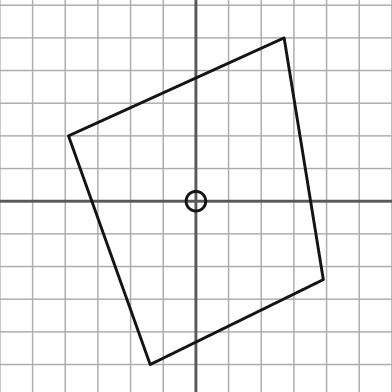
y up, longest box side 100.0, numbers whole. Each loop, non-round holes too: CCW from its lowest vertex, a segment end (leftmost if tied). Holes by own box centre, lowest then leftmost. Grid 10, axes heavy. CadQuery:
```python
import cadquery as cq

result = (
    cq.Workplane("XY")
    .moveTo(-14.0, -50.0)
    .lineTo(39.0, -24.0)
    .lineTo(27.0, 50.0)
    .lineTo(-39.0, 20.0)
    .close()
    .moveTo(0.0, 0.0)
    .circle(3.0)
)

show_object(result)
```